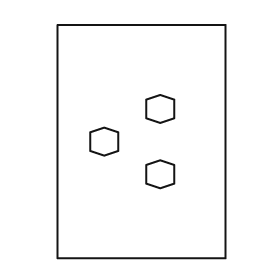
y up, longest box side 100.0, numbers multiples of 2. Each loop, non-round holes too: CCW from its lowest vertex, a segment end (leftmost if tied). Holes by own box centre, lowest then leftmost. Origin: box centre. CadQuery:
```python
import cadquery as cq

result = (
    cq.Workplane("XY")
    .moveTo(-36.0, -50.0)
    .lineTo(36.0, -50.0)
    .lineTo(36.0, 50.0)
    .lineTo(-36.0, 50.0)
    .close()
    .moveTo(8.0, -20.0)
    .lineTo(14.0, -18.0)
    .lineTo(14.0, -10.0)
    .lineTo(8.0, -8.0)
    .lineTo(2.0, -10.0)
    .lineTo(2.0, -18.0)
    .close()
    .moveTo(-16.0, -6.0)
    .lineTo(-10.0, -4.0)
    .lineTo(-10.0, 4.0)
    .lineTo(-16.0, 6.0)
    .lineTo(-22.0, 4.0)
    .lineTo(-22.0, -4.0)
    .close()
    .moveTo(8.0, 8.0)
    .lineTo(14.0, 10.0)
    .lineTo(14.0, 18.0)
    .lineTo(8.0, 20.0)
    .lineTo(2.0, 18.0)
    .lineTo(2.0, 10.0)
    .close()
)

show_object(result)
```